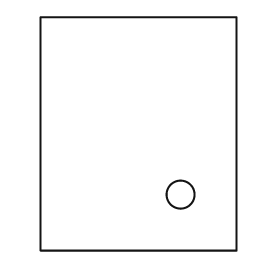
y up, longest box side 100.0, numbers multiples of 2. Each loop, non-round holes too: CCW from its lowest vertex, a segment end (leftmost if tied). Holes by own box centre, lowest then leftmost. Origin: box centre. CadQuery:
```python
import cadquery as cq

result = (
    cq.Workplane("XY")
    .moveTo(-42.0, -50.0)
    .lineTo(42.0, -50.0)
    .lineTo(42.0, 50.0)
    .lineTo(-42.0, 50.0)
    .close()
    .moveTo(18.0, -26.0)
    .circle(6.0)
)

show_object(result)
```